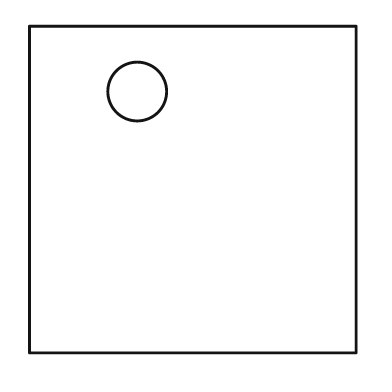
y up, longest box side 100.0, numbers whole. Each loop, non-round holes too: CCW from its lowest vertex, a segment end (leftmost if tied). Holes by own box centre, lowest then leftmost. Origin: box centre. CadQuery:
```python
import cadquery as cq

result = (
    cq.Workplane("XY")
    .moveTo(-50.0, -50.0)
    .lineTo(50.0, -50.0)
    .lineTo(50.0, 50.0)
    .lineTo(-50.0, 50.0)
    .close()
    .moveTo(-17.0, 30.0)
    .circle(9.0)
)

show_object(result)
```